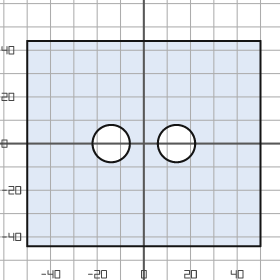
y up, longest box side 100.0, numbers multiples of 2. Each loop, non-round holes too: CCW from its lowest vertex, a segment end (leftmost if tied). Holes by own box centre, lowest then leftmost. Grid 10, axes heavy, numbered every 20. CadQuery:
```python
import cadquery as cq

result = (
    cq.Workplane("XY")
    .moveTo(-50.0, -44.0)
    .lineTo(50.0, -44.0)
    .lineTo(50.0, 44.0)
    .lineTo(-50.0, 44.0)
    .close()
    .moveTo(-14.0, 0.0)
    .circle(8.0)
    .moveTo(14.0, 0.0)
    .circle(8.0)
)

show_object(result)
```